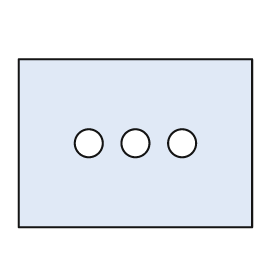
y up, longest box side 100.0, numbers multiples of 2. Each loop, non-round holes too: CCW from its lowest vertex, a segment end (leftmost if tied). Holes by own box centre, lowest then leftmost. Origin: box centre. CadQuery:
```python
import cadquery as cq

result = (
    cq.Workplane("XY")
    .moveTo(-50.0, -36.0)
    .lineTo(50.0, -36.0)
    .lineTo(50.0, 36.0)
    .lineTo(-50.0, 36.0)
    .close()
    .moveTo(-20.0, 0.0)
    .circle(6.0)
    .moveTo(0.0, 0.0)
    .circle(6.0)
    .moveTo(20.0, 0.0)
    .circle(6.0)
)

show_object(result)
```